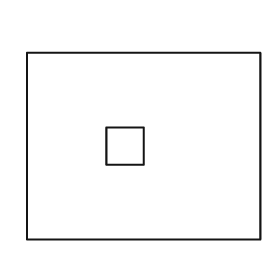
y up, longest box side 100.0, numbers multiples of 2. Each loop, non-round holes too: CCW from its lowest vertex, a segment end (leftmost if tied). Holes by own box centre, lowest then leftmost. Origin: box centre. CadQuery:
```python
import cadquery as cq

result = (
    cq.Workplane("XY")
    .moveTo(-50.0, -40.0)
    .lineTo(50.0, -40.0)
    .lineTo(50.0, 40.0)
    .lineTo(-50.0, 40.0)
    .close()
    .moveTo(-16.0, -8.0)
    .lineTo(0.0, -8.0)
    .lineTo(0.0, 8.0)
    .lineTo(-16.0, 8.0)
    .close()
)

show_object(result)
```